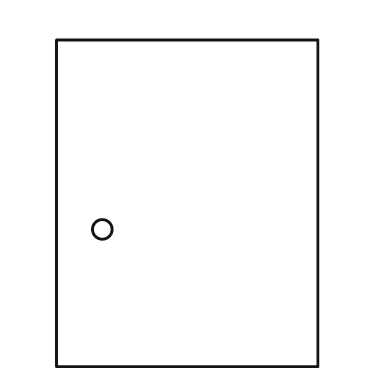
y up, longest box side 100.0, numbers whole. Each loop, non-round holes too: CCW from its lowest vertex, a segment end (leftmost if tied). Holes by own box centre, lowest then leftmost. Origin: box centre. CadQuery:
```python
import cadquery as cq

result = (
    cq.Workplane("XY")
    .moveTo(-40.0, -50.0)
    .lineTo(40.0, -50.0)
    .lineTo(40.0, 50.0)
    .lineTo(-40.0, 50.0)
    .close()
    .moveTo(-26.0, -8.0)
    .circle(3.0)
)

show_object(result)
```